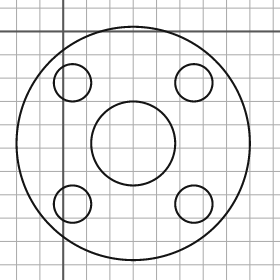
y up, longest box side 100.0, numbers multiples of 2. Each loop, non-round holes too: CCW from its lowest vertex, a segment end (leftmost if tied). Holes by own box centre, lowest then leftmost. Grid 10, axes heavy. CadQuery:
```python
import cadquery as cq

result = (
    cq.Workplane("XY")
    .moveTo(30.0, -48.0)
    .circle(50.0)
    .moveTo(4.0, -74.0)
    .circle(8.0)
    .moveTo(56.0, -74.0)
    .circle(8.0)
    .moveTo(30.0, -48.0)
    .circle(18.0)
    .moveTo(4.0, -22.0)
    .circle(8.0)
    .moveTo(56.0, -22.0)
    .circle(8.0)
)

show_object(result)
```